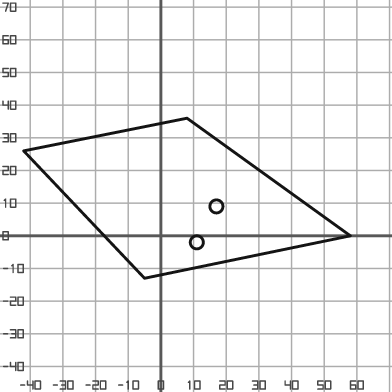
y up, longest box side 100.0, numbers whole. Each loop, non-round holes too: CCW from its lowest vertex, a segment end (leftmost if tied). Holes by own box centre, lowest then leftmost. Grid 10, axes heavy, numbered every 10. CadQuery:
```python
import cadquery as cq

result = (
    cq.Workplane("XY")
    .moveTo(-5.0, -13.0)
    .lineTo(58.0, 0.0)
    .lineTo(8.0, 36.0)
    .lineTo(-42.0, 26.0)
    .close()
    .moveTo(11.0, -2.0)
    .circle(2.0)
    .moveTo(17.0, 9.0)
    .circle(2.0)
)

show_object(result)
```